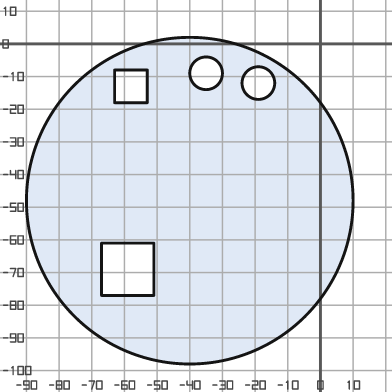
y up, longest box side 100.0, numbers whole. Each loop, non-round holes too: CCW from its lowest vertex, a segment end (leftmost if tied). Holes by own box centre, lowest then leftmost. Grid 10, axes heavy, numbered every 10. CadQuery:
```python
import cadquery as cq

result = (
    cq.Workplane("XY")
    .moveTo(-40.0, -48.0)
    .circle(50.0)
    .moveTo(-67.0, -77.0)
    .lineTo(-51.0, -77.0)
    .lineTo(-51.0, -61.0)
    .lineTo(-67.0, -61.0)
    .close()
    .moveTo(-63.0, -18.0)
    .lineTo(-53.0, -18.0)
    .lineTo(-53.0, -8.0)
    .lineTo(-63.0, -8.0)
    .close()
    .moveTo(-19.0, -12.0)
    .circle(5.0)
    .moveTo(-35.0, -9.0)
    .circle(5.0)
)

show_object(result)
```